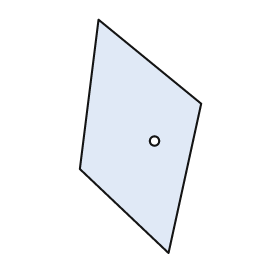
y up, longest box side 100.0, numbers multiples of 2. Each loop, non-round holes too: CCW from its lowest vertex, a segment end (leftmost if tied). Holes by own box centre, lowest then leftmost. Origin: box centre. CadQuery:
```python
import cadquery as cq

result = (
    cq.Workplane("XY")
    .moveTo(12.0, -50.0)
    .lineTo(26.0, 14.0)
    .lineTo(-18.0, 50.0)
    .lineTo(-26.0, -14.0)
    .close()
    .moveTo(6.0, -2.0)
    .circle(2.0)
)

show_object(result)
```